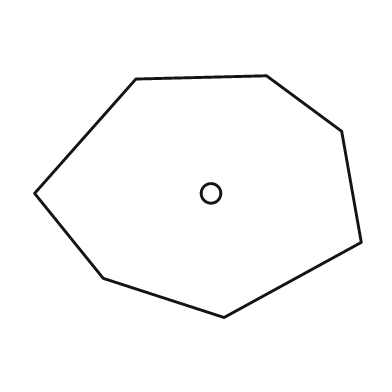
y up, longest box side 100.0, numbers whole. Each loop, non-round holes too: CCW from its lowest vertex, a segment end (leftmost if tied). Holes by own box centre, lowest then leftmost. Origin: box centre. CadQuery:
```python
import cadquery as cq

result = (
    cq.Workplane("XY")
    .moveTo(8.0, -37.0)
    .lineTo(50.0, -14.0)
    .lineTo(44.0, 20.0)
    .lineTo(21.0, 37.0)
    .lineTo(-19.0, 36.0)
    .lineTo(-50.0, 1.0)
    .lineTo(-29.0, -25.0)
    .close()
    .moveTo(4.0, 1.0)
    .circle(3.0)
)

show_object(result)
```